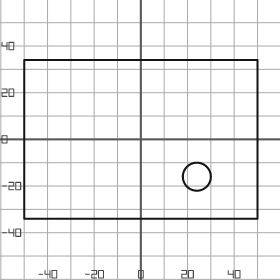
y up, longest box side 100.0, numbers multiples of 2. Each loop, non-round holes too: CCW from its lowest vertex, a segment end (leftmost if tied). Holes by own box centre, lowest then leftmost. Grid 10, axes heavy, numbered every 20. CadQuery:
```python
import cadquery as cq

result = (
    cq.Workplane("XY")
    .moveTo(-50.0, -34.0)
    .lineTo(50.0, -34.0)
    .lineTo(50.0, 34.0)
    .lineTo(-50.0, 34.0)
    .close()
    .moveTo(24.0, -16.0)
    .circle(6.0)
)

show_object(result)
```